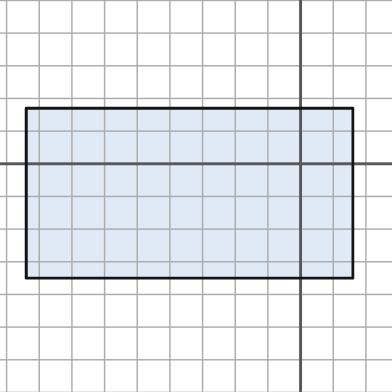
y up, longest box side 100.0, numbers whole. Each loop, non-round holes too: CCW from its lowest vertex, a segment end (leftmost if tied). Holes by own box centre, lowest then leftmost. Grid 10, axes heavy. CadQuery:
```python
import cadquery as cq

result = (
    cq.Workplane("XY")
    .moveTo(-84.0, -35.0)
    .lineTo(16.0, -35.0)
    .lineTo(16.0, 17.0)
    .lineTo(-84.0, 17.0)
    .close()
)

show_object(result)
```